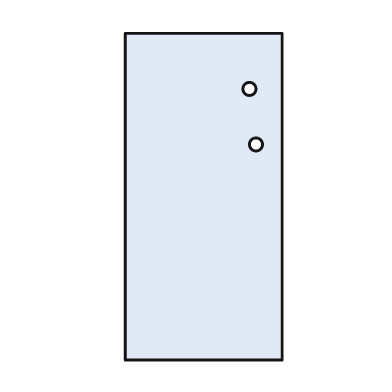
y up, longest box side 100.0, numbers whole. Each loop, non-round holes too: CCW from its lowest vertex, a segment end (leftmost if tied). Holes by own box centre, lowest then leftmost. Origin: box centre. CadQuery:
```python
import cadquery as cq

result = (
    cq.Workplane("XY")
    .moveTo(-24.0, -50.0)
    .lineTo(24.0, -50.0)
    .lineTo(24.0, 50.0)
    .lineTo(-24.0, 50.0)
    .close()
    .moveTo(16.0, 16.0)
    .circle(2.0)
    .moveTo(14.0, 33.0)
    .circle(2.0)
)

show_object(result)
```